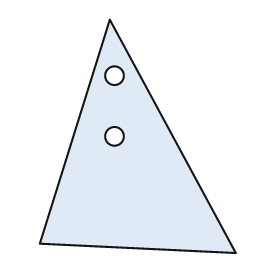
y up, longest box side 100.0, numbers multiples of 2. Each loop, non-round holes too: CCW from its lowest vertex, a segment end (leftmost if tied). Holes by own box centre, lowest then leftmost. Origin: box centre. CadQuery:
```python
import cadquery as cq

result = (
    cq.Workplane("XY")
    .moveTo(42.0, -50.0)
    .lineTo(-12.0, 50.0)
    .lineTo(-42.0, -46.0)
    .close()
    .moveTo(-10.0, 0.0)
    .circle(4.0)
    .moveTo(-10.0, 26.0)
    .circle(4.0)
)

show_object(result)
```